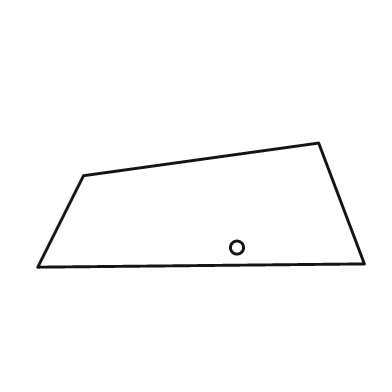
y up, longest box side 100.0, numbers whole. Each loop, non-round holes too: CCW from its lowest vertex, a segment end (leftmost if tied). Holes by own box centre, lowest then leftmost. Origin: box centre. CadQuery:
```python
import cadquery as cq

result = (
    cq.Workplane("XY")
    .moveTo(-50.0, -19.0)
    .lineTo(50.0, -18.0)
    .lineTo(36.0, 19.0)
    .lineTo(-36.0, 9.0)
    .close()
    .moveTo(11.0, -13.0)
    .circle(2.0)
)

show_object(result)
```